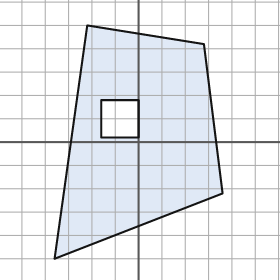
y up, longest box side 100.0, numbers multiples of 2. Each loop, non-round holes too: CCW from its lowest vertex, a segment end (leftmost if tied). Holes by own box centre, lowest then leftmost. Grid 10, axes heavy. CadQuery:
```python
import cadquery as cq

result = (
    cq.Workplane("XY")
    .moveTo(-36.0, -50.0)
    .lineTo(36.0, -22.0)
    .lineTo(28.0, 42.0)
    .lineTo(-22.0, 50.0)
    .close()
    .moveTo(-16.0, 2.0)
    .lineTo(0.0, 2.0)
    .lineTo(0.0, 18.0)
    .lineTo(-16.0, 18.0)
    .close()
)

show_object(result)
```